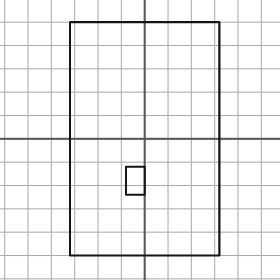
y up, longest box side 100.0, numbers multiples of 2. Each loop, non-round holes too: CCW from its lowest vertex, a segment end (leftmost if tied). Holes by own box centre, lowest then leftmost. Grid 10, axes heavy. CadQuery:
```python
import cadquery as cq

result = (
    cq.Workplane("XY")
    .moveTo(-32.0, -50.0)
    .lineTo(32.0, -50.0)
    .lineTo(32.0, 50.0)
    .lineTo(-32.0, 50.0)
    .close()
    .moveTo(-8.0, -24.0)
    .lineTo(0.0, -24.0)
    .lineTo(0.0, -12.0)
    .lineTo(-8.0, -12.0)
    .close()
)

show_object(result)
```